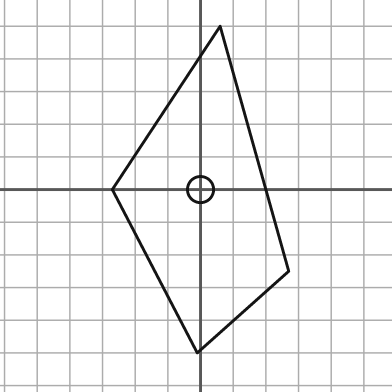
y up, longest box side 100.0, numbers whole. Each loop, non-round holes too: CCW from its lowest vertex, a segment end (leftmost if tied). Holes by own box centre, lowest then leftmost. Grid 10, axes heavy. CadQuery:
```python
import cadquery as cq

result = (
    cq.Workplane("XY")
    .moveTo(-1.0, -50.0)
    .lineTo(27.0, -25.0)
    .lineTo(6.0, 50.0)
    .lineTo(-27.0, 0.0)
    .close()
    .moveTo(0.0, 0.0)
    .circle(4.0)
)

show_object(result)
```